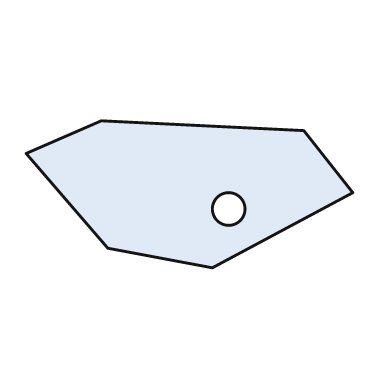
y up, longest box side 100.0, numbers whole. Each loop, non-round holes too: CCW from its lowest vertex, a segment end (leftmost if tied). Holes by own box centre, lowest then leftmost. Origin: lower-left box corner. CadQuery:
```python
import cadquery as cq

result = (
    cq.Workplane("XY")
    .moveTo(57.0, 0.0)
    .lineTo(100.0, 23.0)
    .lineTo(85.0, 42.0)
    .lineTo(23.0, 45.0)
    .lineTo(0.0, 35.0)
    .lineTo(25.0, 6.0)
    .close()
    .moveTo(62.0, 18.0)
    .circle(5.0)
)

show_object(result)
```